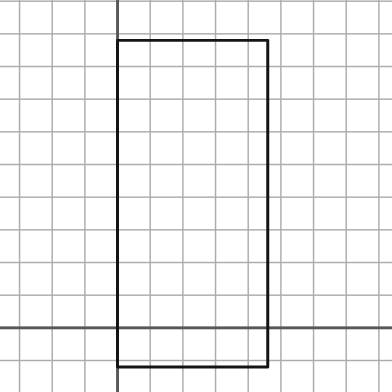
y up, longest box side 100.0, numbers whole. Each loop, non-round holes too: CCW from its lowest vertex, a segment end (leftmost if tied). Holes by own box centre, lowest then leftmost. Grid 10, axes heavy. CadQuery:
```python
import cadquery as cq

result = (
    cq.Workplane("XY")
    .moveTo(0.0, -12.0)
    .lineTo(46.0, -12.0)
    .lineTo(46.0, 88.0)
    .lineTo(0.0, 88.0)
    .close()
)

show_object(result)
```